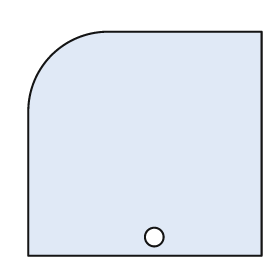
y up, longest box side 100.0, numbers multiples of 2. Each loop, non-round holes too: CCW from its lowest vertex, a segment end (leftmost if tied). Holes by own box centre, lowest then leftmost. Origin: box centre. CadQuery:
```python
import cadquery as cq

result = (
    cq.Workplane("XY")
    .moveTo(-50.0, -48.0)
    .lineTo(50.0, -48.0)
    .lineTo(50.0, 48.0)
    .lineTo(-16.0, 48.0)
    .threePointArc((-40.0, 38.0), (-50.0, 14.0))
    .close()
    .moveTo(4.0, -40.0)
    .circle(4.0)
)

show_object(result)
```